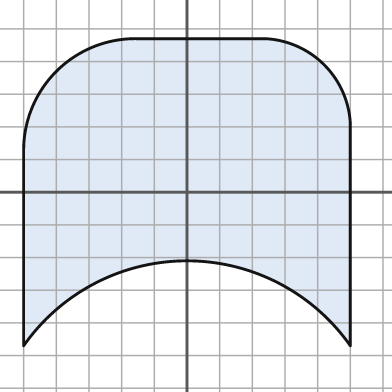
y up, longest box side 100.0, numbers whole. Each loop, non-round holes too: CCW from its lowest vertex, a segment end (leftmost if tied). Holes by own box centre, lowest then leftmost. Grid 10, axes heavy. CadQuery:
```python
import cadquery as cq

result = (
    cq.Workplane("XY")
    .moveTo(-50.0, -47.0)
    .threePointArc((0.0, -21.0), (50.0, -47.0))
    .lineTo(50.0, 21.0)
    .threePointArc((42.0, 39.0), (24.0, 47.0))
    .lineTo(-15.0, 47.0)
    .threePointArc((-40.0, 37.0), (-50.0, 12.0))
    .close()
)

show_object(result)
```